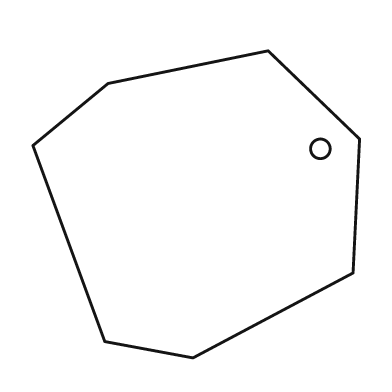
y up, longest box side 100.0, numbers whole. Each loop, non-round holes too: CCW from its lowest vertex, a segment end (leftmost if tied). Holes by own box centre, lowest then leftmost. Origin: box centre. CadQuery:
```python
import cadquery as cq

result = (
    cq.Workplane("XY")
    .moveTo(-1.0, -47.0)
    .lineTo(48.0, -21.0)
    .lineTo(50.0, 20.0)
    .lineTo(22.0, 47.0)
    .lineTo(-27.0, 37.0)
    .lineTo(-50.0, 18.0)
    .lineTo(-28.0, -42.0)
    .close()
    .moveTo(38.0, 17.0)
    .circle(3.0)
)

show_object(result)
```